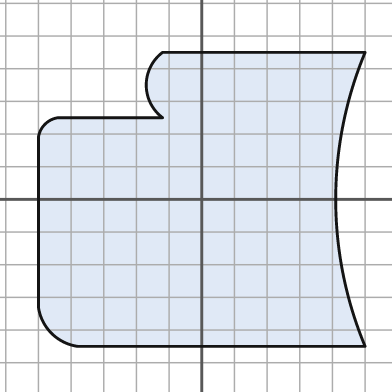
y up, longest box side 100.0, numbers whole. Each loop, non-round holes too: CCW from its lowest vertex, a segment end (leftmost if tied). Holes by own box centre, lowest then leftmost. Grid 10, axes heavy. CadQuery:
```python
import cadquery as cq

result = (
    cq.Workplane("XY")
    .moveTo(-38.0, -45.0)
    .lineTo(50.0, -45.0)
    .threePointArc((41.0, 0.0), (50.0, 45.0))
    .lineTo(-12.0, 45.0)
    .threePointArc((-17.0, 35.0), (-12.0, 25.0))
    .lineTo(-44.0, 25.0)
    .threePointArc((-48.0, 23.0), (-50.0, 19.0))
    .lineTo(-50.0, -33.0)
    .threePointArc((-46.0, -41.0), (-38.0, -45.0))
    .close()
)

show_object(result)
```